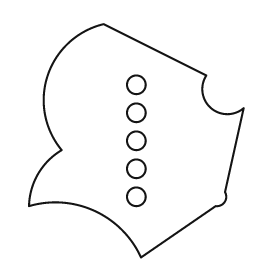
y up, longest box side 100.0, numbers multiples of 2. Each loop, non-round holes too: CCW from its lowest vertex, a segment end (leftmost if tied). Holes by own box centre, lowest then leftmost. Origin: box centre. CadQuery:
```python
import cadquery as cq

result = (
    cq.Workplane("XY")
    .moveTo(2.0, -50.0)
    .lineTo(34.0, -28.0)
    .threePointArc((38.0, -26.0), (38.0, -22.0))
    .lineTo(46.0, 14.0)
    .threePointArc((32.0, 14.0), (30.0, 28.0))
    .lineTo(-14.0, 50.0)
    .threePointArc((-38.0, 28.0), (-32.0, -4.0))
    .threePointArc((-42.0, -14.0), (-46.0, -28.0))
    .threePointArc((-18.0, -30.0), (2.0, -50.0))
    .close()
    .moveTo(0.0, -24.0)
    .circle(4.0)
    .moveTo(0.0, -12.0)
    .circle(4.0)
    .moveTo(0.0, 0.0)
    .circle(4.0)
    .moveTo(0.0, 12.0)
    .circle(4.0)
    .moveTo(0.0, 24.0)
    .circle(4.0)
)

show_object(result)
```